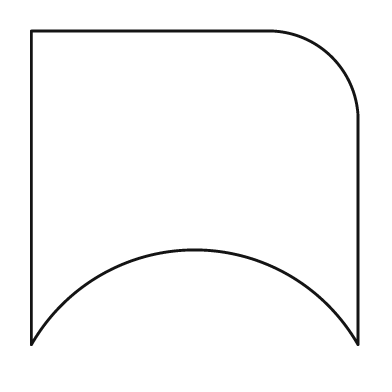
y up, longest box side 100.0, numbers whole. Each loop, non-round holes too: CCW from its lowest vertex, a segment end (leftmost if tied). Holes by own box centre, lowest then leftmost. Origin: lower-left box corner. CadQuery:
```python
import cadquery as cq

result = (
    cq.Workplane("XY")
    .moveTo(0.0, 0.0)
    .threePointArc((50.0, 29.0), (100.0, 0.0))
    .lineTo(100.0, 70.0)
    .threePointArc((92.0, 88.0), (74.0, 96.0))
    .lineTo(0.0, 96.0)
    .close()
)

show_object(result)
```